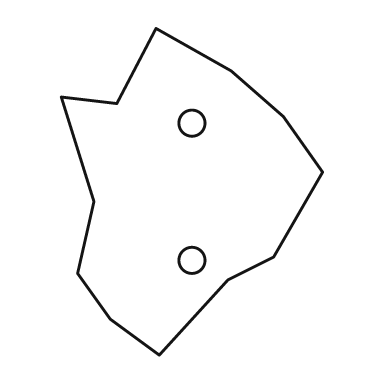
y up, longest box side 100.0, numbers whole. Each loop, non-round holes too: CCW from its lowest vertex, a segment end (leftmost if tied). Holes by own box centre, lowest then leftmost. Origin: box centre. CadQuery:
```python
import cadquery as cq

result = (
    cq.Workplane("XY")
    .moveTo(-10.0, -50.0)
    .lineTo(11.0, -27.0)
    .lineTo(25.0, -20.0)
    .lineTo(40.0, 6.0)
    .lineTo(28.0, 23.0)
    .lineTo(12.0, 37.0)
    .lineTo(-11.0, 50.0)
    .lineTo(-23.0, 27.0)
    .lineTo(-40.0, 29.0)
    .lineTo(-30.0, -3.0)
    .lineTo(-35.0, -25.0)
    .lineTo(-25.0, -39.0)
    .close()
    .moveTo(0.0, -21.0)
    .circle(4.0)
    .moveTo(0.0, 21.0)
    .circle(4.0)
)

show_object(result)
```